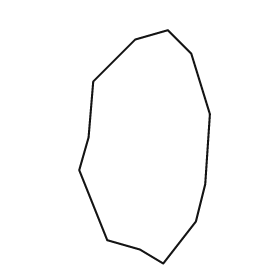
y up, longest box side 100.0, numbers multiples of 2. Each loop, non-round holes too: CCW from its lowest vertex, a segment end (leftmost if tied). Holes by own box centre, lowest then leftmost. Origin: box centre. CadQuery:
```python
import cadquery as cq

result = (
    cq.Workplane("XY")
    .moveTo(8.0, -50.0)
    .lineTo(22.0, -32.0)
    .lineTo(26.0, -16.0)
    .lineTo(28.0, 14.0)
    .lineTo(20.0, 40.0)
    .lineTo(10.0, 50.0)
    .lineTo(-4.0, 46.0)
    .lineTo(-22.0, 28.0)
    .lineTo(-24.0, 4.0)
    .lineTo(-28.0, -10.0)
    .lineTo(-16.0, -40.0)
    .lineTo(-2.0, -44.0)
    .close()
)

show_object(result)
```